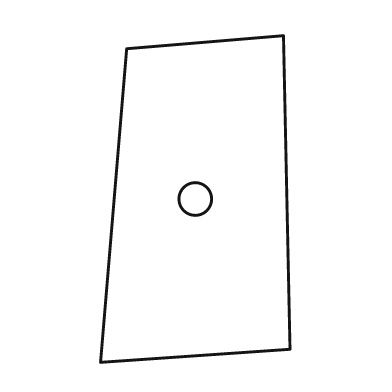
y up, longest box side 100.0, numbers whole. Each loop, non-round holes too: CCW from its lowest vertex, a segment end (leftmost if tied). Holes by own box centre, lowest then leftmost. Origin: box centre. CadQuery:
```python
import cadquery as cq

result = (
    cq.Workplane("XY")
    .moveTo(-29.0, -50.0)
    .lineTo(29.0, -46.0)
    .lineTo(27.0, 50.0)
    .lineTo(-21.0, 46.0)
    .close()
    .moveTo(0.0, 0.0)
    .circle(5.0)
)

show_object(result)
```